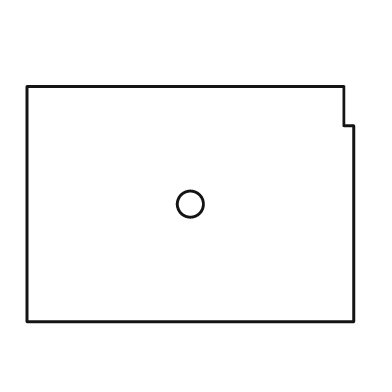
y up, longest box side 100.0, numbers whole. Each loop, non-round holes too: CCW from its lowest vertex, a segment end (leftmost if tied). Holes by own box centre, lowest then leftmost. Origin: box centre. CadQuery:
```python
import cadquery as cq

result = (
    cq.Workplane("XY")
    .moveTo(-50.0, -36.0)
    .lineTo(50.0, -36.0)
    .lineTo(50.0, 24.0)
    .lineTo(47.0, 24.0)
    .lineTo(47.0, 36.0)
    .lineTo(-50.0, 36.0)
    .close()
    .moveTo(0.0, 0.0)
    .circle(4.0)
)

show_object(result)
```